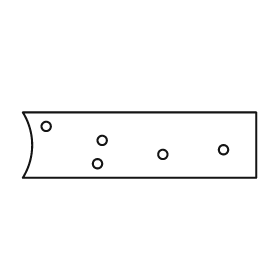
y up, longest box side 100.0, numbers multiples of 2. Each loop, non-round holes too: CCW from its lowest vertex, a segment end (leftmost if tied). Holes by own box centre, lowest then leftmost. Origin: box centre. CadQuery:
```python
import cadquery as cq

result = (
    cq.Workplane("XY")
    .moveTo(-50.0, -14.0)
    .lineTo(50.0, -14.0)
    .lineTo(50.0, 14.0)
    .lineTo(-50.0, 14.0)
    .threePointArc((-46.0, 0.0), (-50.0, -14.0))
    .close()
    .moveTo(-18.0, -8.0)
    .circle(2.0)
    .moveTo(10.0, -4.0)
    .circle(2.0)
    .moveTo(36.0, -2.0)
    .circle(2.0)
    .moveTo(-16.0, 2.0)
    .circle(2.0)
    .moveTo(-40.0, 8.0)
    .circle(2.0)
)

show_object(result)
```